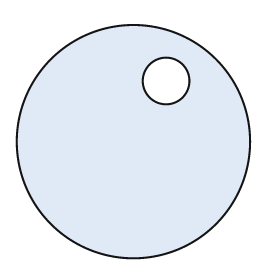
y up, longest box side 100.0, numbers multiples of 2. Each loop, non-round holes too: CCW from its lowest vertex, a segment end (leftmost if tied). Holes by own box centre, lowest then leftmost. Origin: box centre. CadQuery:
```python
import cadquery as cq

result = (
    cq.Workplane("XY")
    .moveTo(0.0, 0.0)
    .circle(50.0)
    .moveTo(14.0, 26.0)
    .circle(10.0)
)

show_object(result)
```